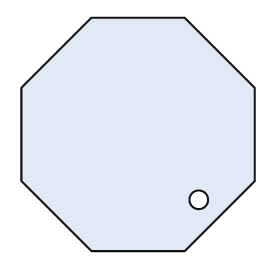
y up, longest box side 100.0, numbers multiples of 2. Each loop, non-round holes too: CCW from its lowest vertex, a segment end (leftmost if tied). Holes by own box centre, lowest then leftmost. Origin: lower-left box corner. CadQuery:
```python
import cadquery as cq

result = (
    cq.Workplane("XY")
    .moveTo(30.0, 0.0)
    .lineTo(70.0, 0.0)
    .lineTo(100.0, 30.0)
    .lineTo(100.0, 70.0)
    .lineTo(70.0, 100.0)
    .lineTo(30.0, 100.0)
    .lineTo(0.0, 70.0)
    .lineTo(0.0, 30.0)
    .close()
    .moveTo(76.0, 22.0)
    .circle(4.0)
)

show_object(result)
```